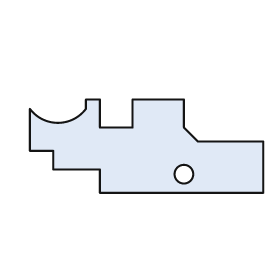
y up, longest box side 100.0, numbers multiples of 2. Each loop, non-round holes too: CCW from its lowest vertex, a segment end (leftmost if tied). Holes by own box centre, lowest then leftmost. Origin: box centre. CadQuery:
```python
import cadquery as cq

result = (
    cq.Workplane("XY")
    .moveTo(-20.0, -20.0)
    .lineTo(50.0, -20.0)
    .lineTo(50.0, 2.0)
    .lineTo(22.0, 2.0)
    .lineTo(16.0, 8.0)
    .lineTo(16.0, 20.0)
    .lineTo(-6.0, 20.0)
    .lineTo(-6.0, 8.0)
    .lineTo(-20.0, 8.0)
    .lineTo(-20.0, 20.0)
    .lineTo(-26.0, 20.0)
    .lineTo(-26.0, 16.0)
    .threePointArc((-38.0, 10.0), (-50.0, 16.0))
    .lineTo(-50.0, -2.0)
    .lineTo(-40.0, -2.0)
    .lineTo(-40.0, -10.0)
    .lineTo(-20.0, -10.0)
    .close()
    .moveTo(16.0, -12.0)
    .circle(4.0)
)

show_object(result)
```